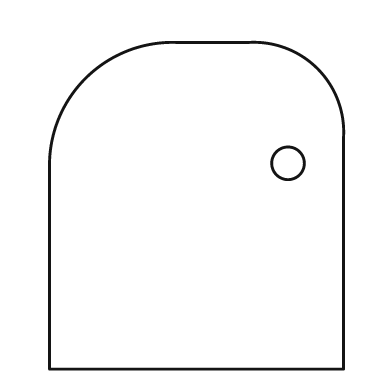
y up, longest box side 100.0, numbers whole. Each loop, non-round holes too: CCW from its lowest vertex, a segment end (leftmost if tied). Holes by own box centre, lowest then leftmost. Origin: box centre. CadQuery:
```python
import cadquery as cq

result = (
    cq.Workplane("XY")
    .moveTo(-45.0, -50.0)
    .lineTo(45.0, -50.0)
    .lineTo(45.0, 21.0)
    .threePointArc((37.0, 42.0), (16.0, 50.0))
    .lineTo(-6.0, 50.0)
    .threePointArc((-34.0, 39.0), (-45.0, 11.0))
    .close()
    .moveTo(28.0, 13.0)
    .circle(5.0)
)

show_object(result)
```